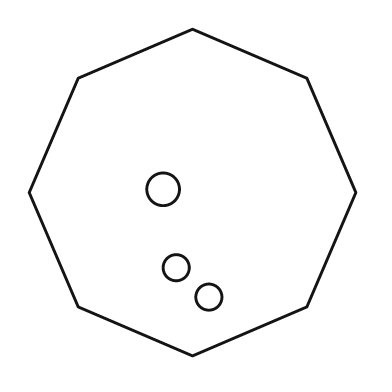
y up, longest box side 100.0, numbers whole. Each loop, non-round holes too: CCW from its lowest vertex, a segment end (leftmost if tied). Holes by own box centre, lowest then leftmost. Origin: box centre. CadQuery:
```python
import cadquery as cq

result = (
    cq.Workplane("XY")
    .moveTo(0.0, -50.0)
    .lineTo(35.0, -35.0)
    .lineTo(50.0, 0.0)
    .lineTo(35.0, 35.0)
    .lineTo(0.0, 50.0)
    .lineTo(-35.0, 35.0)
    .lineTo(-50.0, 0.0)
    .lineTo(-35.0, -35.0)
    .close()
    .moveTo(5.0, -32.0)
    .circle(4.0)
    .moveTo(-5.0, -23.0)
    .circle(4.0)
    .moveTo(-9.0, 1.0)
    .circle(5.0)
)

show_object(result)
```